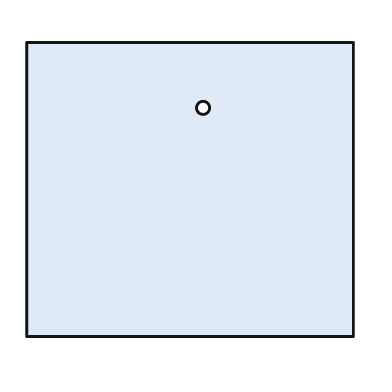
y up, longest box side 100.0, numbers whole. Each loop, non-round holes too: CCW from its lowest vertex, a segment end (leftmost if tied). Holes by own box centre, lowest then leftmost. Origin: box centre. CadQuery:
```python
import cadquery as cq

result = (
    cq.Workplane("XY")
    .moveTo(-50.0, -45.0)
    .lineTo(50.0, -45.0)
    .lineTo(50.0, 45.0)
    .lineTo(-50.0, 45.0)
    .close()
    .moveTo(4.0, 25.0)
    .circle(2.0)
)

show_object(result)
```